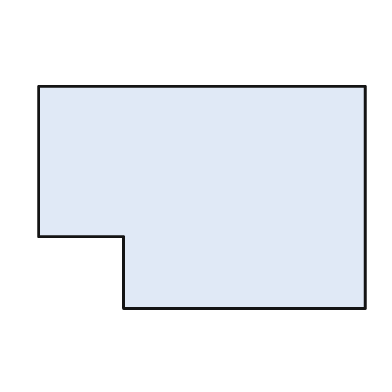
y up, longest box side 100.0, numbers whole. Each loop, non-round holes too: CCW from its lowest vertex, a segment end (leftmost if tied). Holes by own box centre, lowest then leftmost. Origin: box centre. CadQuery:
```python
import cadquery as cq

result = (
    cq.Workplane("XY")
    .moveTo(-24.0, -34.0)
    .lineTo(50.0, -34.0)
    .lineTo(50.0, 34.0)
    .lineTo(-50.0, 34.0)
    .lineTo(-50.0, -12.0)
    .lineTo(-24.0, -12.0)
    .close()
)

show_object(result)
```